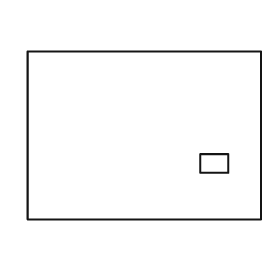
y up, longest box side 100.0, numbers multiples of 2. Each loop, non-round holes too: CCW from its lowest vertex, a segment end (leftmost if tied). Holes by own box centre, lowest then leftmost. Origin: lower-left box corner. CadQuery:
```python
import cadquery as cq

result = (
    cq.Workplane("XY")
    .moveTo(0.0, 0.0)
    .lineTo(100.0, 0.0)
    .lineTo(100.0, 72.0)
    .lineTo(0.0, 72.0)
    .close()
    .moveTo(74.0, 20.0)
    .lineTo(86.0, 20.0)
    .lineTo(86.0, 28.0)
    .lineTo(74.0, 28.0)
    .close()
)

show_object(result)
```